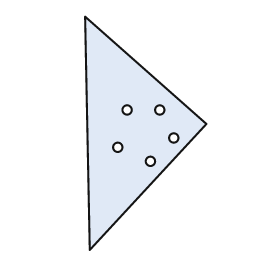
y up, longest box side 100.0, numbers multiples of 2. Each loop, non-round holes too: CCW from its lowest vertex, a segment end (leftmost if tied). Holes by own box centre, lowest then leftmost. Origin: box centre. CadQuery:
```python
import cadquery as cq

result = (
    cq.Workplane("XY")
    .moveTo(-24.0, -50.0)
    .lineTo(26.0, 4.0)
    .lineTo(-26.0, 50.0)
    .close()
    .moveTo(2.0, -12.0)
    .circle(2.0)
    .moveTo(-12.0, -6.0)
    .circle(2.0)
    .moveTo(12.0, -2.0)
    .circle(2.0)
    .moveTo(-8.0, 10.0)
    .circle(2.0)
    .moveTo(6.0, 10.0)
    .circle(2.0)
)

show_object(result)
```